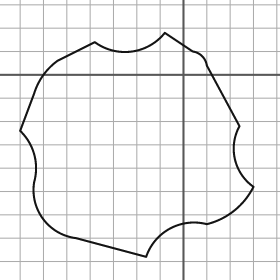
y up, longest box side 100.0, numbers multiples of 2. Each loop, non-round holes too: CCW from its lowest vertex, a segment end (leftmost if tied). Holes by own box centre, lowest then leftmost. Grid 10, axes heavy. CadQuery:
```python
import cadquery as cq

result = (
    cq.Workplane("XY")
    .moveTo(-16.0, -78.0)
    .threePointArc((-6.0, -66.0), (10.0, -64.0))
    .threePointArc((22.0, -58.0), (30.0, -48.0))
    .threePointArc((22.0, -36.0), (24.0, -22.0))
    .lineTo(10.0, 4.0)
    .threePointArc((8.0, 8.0), (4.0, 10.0))
    .lineTo(-8.0, 18.0)
    .threePointArc((-22.0, 10.0), (-38.0, 14.0))
    .lineTo(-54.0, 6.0)
    .threePointArc((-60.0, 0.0), (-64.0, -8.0))
    .lineTo(-70.0, -24.0)
    .threePointArc((-64.0, -34.0), (-64.0, -46.0))
    .threePointArc((-60.0, -62.0), (-46.0, -70.0))
    .close()
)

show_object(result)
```